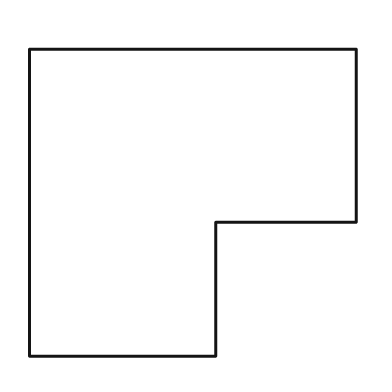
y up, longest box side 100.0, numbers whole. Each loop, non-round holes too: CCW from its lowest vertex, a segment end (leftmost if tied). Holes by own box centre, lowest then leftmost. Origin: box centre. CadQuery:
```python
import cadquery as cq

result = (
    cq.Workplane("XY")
    .moveTo(-50.0, -47.0)
    .lineTo(7.0, -47.0)
    .lineTo(7.0, -6.0)
    .lineTo(50.0, -6.0)
    .lineTo(50.0, 47.0)
    .lineTo(-50.0, 47.0)
    .close()
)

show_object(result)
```